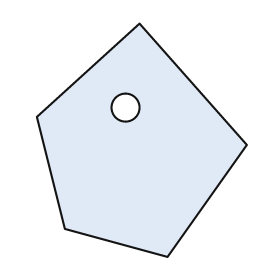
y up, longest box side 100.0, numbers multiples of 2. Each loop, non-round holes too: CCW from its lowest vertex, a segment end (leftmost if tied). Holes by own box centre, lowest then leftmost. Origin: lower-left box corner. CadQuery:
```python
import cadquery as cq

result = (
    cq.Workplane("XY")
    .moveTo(56.0, 0.0)
    .lineTo(90.0, 48.0)
    .lineTo(44.0, 100.0)
    .lineTo(0.0, 60.0)
    .lineTo(12.0, 12.0)
    .close()
    .moveTo(38.0, 64.0)
    .circle(6.0)
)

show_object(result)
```